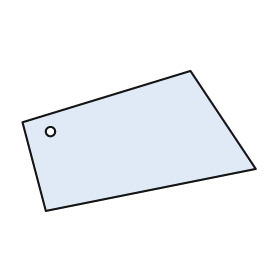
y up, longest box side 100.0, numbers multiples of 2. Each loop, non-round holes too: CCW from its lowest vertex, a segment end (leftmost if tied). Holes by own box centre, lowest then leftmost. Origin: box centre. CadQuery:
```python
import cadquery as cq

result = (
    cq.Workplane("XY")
    .moveTo(-40.0, -30.0)
    .lineTo(50.0, -12.0)
    .lineTo(22.0, 30.0)
    .lineTo(-50.0, 8.0)
    .close()
    .moveTo(-38.0, 4.0)
    .circle(2.0)
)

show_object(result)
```